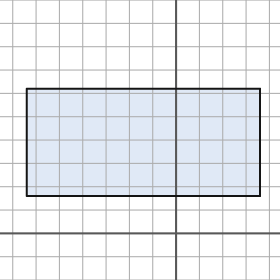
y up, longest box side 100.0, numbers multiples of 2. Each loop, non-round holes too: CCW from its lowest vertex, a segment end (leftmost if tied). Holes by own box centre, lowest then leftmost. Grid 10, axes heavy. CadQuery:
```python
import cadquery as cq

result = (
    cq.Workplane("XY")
    .moveTo(-64.0, 16.0)
    .lineTo(36.0, 16.0)
    .lineTo(36.0, 62.0)
    .lineTo(-64.0, 62.0)
    .close()
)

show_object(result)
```